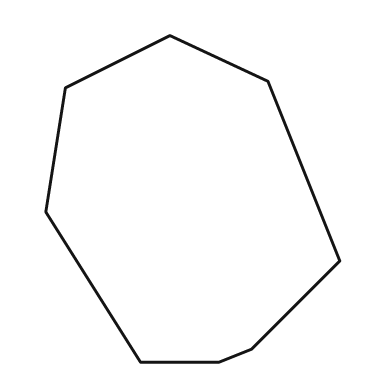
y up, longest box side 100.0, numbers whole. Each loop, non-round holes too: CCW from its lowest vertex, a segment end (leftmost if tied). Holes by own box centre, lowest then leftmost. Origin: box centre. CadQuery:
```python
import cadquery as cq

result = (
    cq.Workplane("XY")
    .moveTo(-16.0, -50.0)
    .lineTo(8.0, -50.0)
    .lineTo(18.0, -46.0)
    .lineTo(45.0, -19.0)
    .lineTo(23.0, 36.0)
    .lineTo(-7.0, 50.0)
    .lineTo(-39.0, 34.0)
    .lineTo(-45.0, -4.0)
    .close()
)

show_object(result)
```